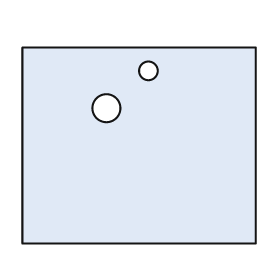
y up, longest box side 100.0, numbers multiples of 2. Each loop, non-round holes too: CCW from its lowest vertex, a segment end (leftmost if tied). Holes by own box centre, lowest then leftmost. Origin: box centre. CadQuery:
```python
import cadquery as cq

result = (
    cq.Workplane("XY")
    .moveTo(-50.0, -42.0)
    .lineTo(50.0, -42.0)
    .lineTo(50.0, 42.0)
    .lineTo(-50.0, 42.0)
    .close()
    .moveTo(-14.0, 16.0)
    .circle(6.0)
    .moveTo(4.0, 32.0)
    .circle(4.0)
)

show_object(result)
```